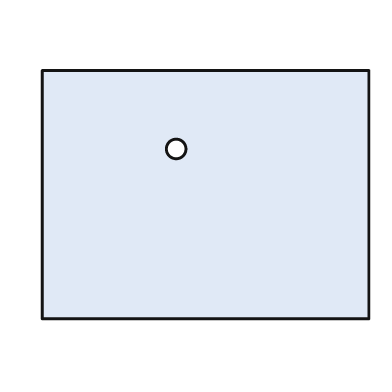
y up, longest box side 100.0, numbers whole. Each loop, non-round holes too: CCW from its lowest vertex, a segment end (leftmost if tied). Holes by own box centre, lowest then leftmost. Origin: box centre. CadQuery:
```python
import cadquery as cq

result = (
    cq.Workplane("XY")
    .moveTo(-50.0, -38.0)
    .lineTo(50.0, -38.0)
    .lineTo(50.0, 38.0)
    .lineTo(-50.0, 38.0)
    .close()
    .moveTo(-9.0, 14.0)
    .circle(3.0)
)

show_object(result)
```